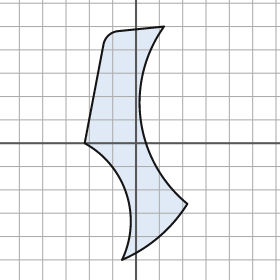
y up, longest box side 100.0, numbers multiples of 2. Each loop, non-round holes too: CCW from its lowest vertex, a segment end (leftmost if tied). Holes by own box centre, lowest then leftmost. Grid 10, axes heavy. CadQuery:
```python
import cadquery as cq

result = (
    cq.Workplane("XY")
    .moveTo(-6.0, -50.0)
    .threePointArc((10.0, -40.0), (22.0, -26.0))
    .threePointArc((2.0, 10.0), (12.0, 50.0))
    .lineTo(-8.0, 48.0)
    .threePointArc((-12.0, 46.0), (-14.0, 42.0))
    .lineTo(-22.0, 0.0)
    .threePointArc((-4.0, -22.0), (-6.0, -50.0))
    .close()
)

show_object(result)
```